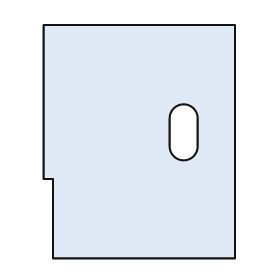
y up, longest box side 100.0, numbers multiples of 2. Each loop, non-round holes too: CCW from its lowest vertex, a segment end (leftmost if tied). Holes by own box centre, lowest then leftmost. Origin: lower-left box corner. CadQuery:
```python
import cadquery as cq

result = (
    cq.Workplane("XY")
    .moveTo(4.0, 0.0)
    .lineTo(82.0, 0.0)
    .lineTo(82.0, 100.0)
    .lineTo(0.0, 100.0)
    .lineTo(0.0, 34.0)
    .lineTo(4.0, 34.0)
    .close()
    .moveTo(54.0, 48.0)
    .threePointArc((60.0, 42.0), (66.0, 48.0))
    .lineTo(66.0, 60.0)
    .threePointArc((60.0, 66.0), (54.0, 60.0))
    .close()
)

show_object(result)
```